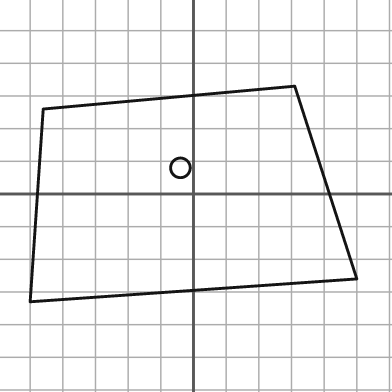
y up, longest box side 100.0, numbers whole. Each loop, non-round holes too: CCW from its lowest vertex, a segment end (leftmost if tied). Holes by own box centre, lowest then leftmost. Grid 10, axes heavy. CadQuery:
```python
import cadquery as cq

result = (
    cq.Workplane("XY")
    .moveTo(-50.0, -33.0)
    .lineTo(50.0, -26.0)
    .lineTo(31.0, 33.0)
    .lineTo(-46.0, 26.0)
    .close()
    .moveTo(-4.0, 8.0)
    .circle(3.0)
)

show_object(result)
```